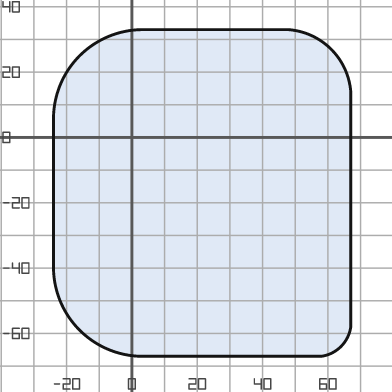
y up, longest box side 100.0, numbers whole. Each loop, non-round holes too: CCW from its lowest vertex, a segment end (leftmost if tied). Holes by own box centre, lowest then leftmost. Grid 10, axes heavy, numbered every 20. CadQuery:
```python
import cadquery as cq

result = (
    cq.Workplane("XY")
    .moveTo(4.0, -67.0)
    .lineTo(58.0, -67.0)
    .threePointArc((64.0, -64.0), (67.0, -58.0))
    .lineTo(67.0, 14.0)
    .threePointArc((61.0, 27.0), (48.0, 33.0))
    .lineTo(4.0, 33.0)
    .threePointArc((-16.0, 25.0), (-24.0, 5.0))
    .lineTo(-24.0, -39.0)
    .threePointArc((-16.0, -59.0), (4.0, -67.0))
    .close()
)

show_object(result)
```